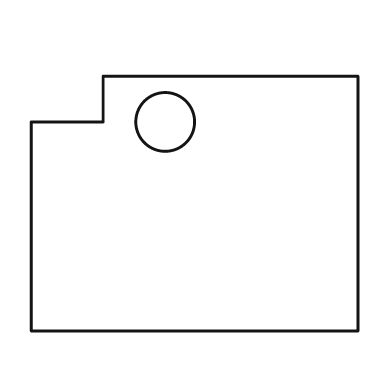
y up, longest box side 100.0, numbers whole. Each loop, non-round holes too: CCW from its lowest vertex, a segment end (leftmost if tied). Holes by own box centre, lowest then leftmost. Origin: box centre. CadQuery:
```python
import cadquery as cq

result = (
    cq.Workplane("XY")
    .moveTo(-50.0, -39.0)
    .lineTo(50.0, -39.0)
    .lineTo(50.0, 39.0)
    .lineTo(-28.0, 39.0)
    .lineTo(-28.0, 25.0)
    .lineTo(-50.0, 25.0)
    .close()
    .moveTo(-9.0, 25.0)
    .circle(9.0)
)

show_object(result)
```